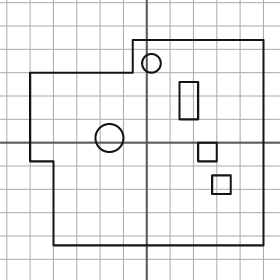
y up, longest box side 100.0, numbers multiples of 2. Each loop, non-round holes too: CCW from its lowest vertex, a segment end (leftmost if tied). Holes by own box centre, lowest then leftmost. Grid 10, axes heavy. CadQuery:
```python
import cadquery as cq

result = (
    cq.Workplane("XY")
    .moveTo(-40.0, -44.0)
    .lineTo(50.0, -44.0)
    .lineTo(50.0, 44.0)
    .lineTo(-6.0, 44.0)
    .lineTo(-6.0, 30.0)
    .lineTo(-50.0, 30.0)
    .lineTo(-50.0, -8.0)
    .lineTo(-40.0, -8.0)
    .close()
    .moveTo(28.0, -22.0)
    .lineTo(36.0, -22.0)
    .lineTo(36.0, -14.0)
    .lineTo(28.0, -14.0)
    .close()
    .moveTo(22.0, -8.0)
    .lineTo(30.0, -8.0)
    .lineTo(30.0, 0.0)
    .lineTo(22.0, 0.0)
    .close()
    .moveTo(-16.0, 2.0)
    .circle(6.0)
    .moveTo(14.0, 10.0)
    .lineTo(22.0, 10.0)
    .lineTo(22.0, 26.0)
    .lineTo(14.0, 26.0)
    .close()
    .moveTo(2.0, 34.0)
    .circle(4.0)
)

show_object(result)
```